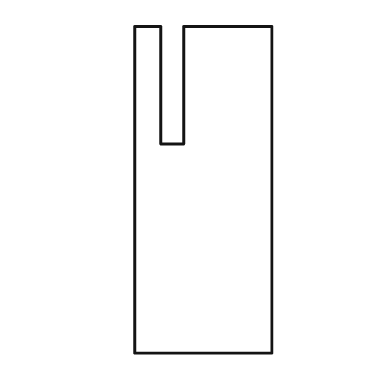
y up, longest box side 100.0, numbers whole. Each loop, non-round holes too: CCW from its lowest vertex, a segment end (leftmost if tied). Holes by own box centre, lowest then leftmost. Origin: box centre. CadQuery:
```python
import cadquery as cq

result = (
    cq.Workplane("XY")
    .moveTo(-21.0, -50.0)
    .lineTo(21.0, -50.0)
    .lineTo(21.0, 50.0)
    .lineTo(-6.0, 50.0)
    .lineTo(-6.0, 14.0)
    .lineTo(-13.0, 14.0)
    .lineTo(-13.0, 50.0)
    .lineTo(-21.0, 50.0)
    .close()
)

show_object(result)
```